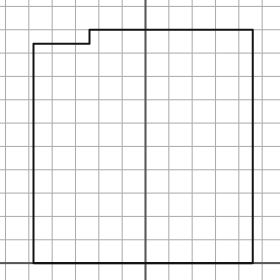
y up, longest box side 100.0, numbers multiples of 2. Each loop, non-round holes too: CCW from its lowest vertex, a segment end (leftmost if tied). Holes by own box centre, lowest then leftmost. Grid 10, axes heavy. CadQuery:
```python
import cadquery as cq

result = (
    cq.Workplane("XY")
    .moveTo(-48.0, 0.0)
    .lineTo(46.0, 0.0)
    .lineTo(46.0, 100.0)
    .lineTo(-24.0, 100.0)
    .lineTo(-24.0, 94.0)
    .lineTo(-48.0, 94.0)
    .close()
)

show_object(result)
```